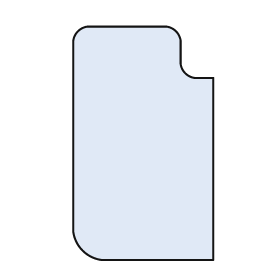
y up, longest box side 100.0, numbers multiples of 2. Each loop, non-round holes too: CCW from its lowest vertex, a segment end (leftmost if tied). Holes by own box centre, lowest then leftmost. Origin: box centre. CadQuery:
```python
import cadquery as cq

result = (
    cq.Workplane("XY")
    .moveTo(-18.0, -50.0)
    .lineTo(30.0, -50.0)
    .lineTo(30.0, 28.0)
    .lineTo(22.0, 28.0)
    .threePointArc((18.0, 30.0), (16.0, 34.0))
    .lineTo(16.0, 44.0)
    .threePointArc((14.0, 48.0), (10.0, 50.0))
    .lineTo(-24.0, 50.0)
    .threePointArc((-28.0, 48.0), (-30.0, 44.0))
    .lineTo(-30.0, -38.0)
    .threePointArc((-26.0, -46.0), (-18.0, -50.0))
    .close()
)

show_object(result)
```